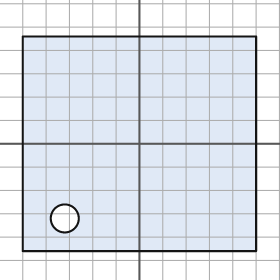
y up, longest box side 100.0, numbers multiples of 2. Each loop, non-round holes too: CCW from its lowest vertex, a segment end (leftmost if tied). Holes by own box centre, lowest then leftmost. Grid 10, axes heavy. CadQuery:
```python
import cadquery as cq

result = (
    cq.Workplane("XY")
    .moveTo(-50.0, -46.0)
    .lineTo(50.0, -46.0)
    .lineTo(50.0, 46.0)
    .lineTo(-50.0, 46.0)
    .close()
    .moveTo(-32.0, -32.0)
    .circle(6.0)
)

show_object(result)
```